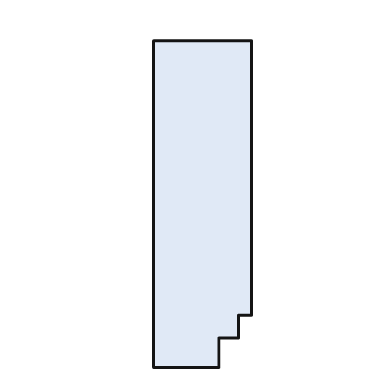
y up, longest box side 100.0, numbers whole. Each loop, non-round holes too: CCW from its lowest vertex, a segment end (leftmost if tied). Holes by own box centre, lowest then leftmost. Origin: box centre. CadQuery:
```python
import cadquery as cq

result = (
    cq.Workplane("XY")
    .moveTo(-15.0, -50.0)
    .lineTo(5.0, -50.0)
    .lineTo(5.0, -41.0)
    .lineTo(11.0, -41.0)
    .lineTo(11.0, -34.0)
    .lineTo(15.0, -34.0)
    .lineTo(15.0, 50.0)
    .lineTo(-15.0, 50.0)
    .close()
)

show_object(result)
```